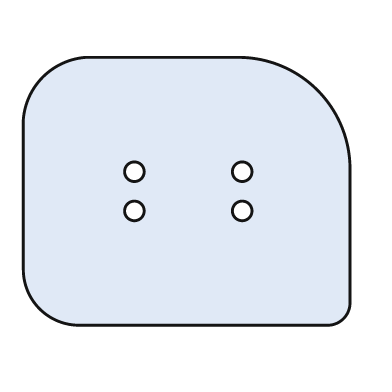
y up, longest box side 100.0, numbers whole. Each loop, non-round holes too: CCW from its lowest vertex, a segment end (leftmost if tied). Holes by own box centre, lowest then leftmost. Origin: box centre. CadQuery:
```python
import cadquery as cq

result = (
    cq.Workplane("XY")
    .moveTo(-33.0, -41.0)
    .lineTo(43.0, -41.0)
    .threePointArc((48.0, -39.0), (50.0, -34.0))
    .lineTo(50.0, 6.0)
    .threePointArc((40.0, 31.0), (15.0, 41.0))
    .lineTo(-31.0, 41.0)
    .threePointArc((-44.0, 35.0), (-50.0, 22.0))
    .lineTo(-50.0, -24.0)
    .threePointArc((-45.0, -36.0), (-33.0, -41.0))
    .close()
    .moveTo(-16.0, -6.0)
    .circle(3.0)
    .moveTo(17.0, -6.0)
    .circle(3.0)
    .moveTo(-16.0, 6.0)
    .circle(3.0)
    .moveTo(17.0, 6.0)
    .circle(3.0)
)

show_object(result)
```